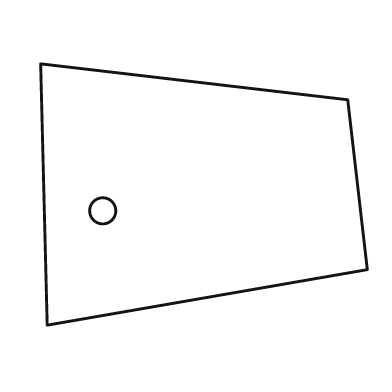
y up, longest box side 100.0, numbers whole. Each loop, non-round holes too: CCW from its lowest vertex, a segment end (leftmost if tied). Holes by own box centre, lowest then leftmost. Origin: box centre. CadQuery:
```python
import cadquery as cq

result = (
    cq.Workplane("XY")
    .moveTo(-48.0, -40.0)
    .lineTo(50.0, -23.0)
    .lineTo(44.0, 29.0)
    .lineTo(-50.0, 40.0)
    .close()
    .moveTo(-31.0, -5.0)
    .circle(4.0)
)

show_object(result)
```